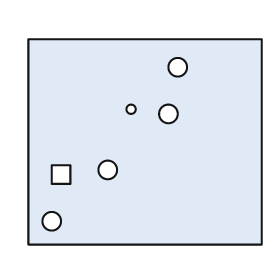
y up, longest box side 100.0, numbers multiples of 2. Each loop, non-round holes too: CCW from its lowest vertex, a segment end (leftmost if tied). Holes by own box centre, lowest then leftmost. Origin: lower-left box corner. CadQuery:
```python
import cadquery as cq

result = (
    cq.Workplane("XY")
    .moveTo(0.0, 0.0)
    .lineTo(100.0, 0.0)
    .lineTo(100.0, 88.0)
    .lineTo(0.0, 88.0)
    .close()
    .moveTo(10.0, 10.0)
    .circle(4.0)
    .moveTo(10.0, 26.0)
    .lineTo(18.0, 26.0)
    .lineTo(18.0, 34.0)
    .lineTo(10.0, 34.0)
    .close()
    .moveTo(34.0, 32.0)
    .circle(4.0)
    .moveTo(60.0, 56.0)
    .circle(4.0)
    .moveTo(44.0, 58.0)
    .circle(2.0)
    .moveTo(64.0, 76.0)
    .circle(4.0)
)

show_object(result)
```